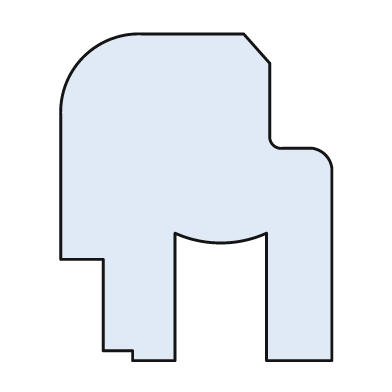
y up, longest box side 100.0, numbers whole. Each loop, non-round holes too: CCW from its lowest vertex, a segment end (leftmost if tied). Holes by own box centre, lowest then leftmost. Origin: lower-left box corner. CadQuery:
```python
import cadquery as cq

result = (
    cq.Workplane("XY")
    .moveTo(22.0, 0.0)
    .lineTo(35.0, 0.0)
    .lineTo(35.0, 39.0)
    .threePointArc((49.0, 36.0), (63.0, 39.0))
    .lineTo(63.0, 0.0)
    .lineTo(83.0, 0.0)
    .lineTo(83.0, 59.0)
    .threePointArc((81.0, 63.0), (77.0, 65.0))
    .lineTo(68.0, 65.0)
    .threePointArc((65.0, 66.0), (64.0, 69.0))
    .lineTo(64.0, 91.0)
    .lineTo(56.0, 100.0)
    .lineTo(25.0, 100.0)
    .threePointArc((7.0, 93.0), (0.0, 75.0))
    .lineTo(0.0, 31.0)
    .lineTo(13.0, 31.0)
    .lineTo(13.0, 3.0)
    .lineTo(22.0, 3.0)
    .close()
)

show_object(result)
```